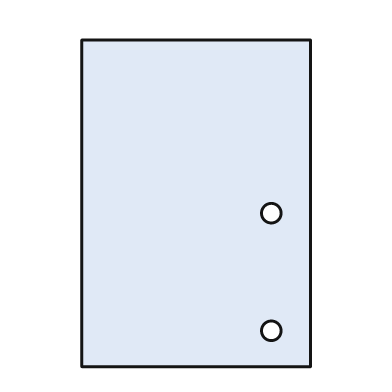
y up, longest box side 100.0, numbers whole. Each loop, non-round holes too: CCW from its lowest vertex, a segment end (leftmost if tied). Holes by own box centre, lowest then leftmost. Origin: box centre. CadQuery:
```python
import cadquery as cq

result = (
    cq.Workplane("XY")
    .moveTo(-35.0, -50.0)
    .lineTo(35.0, -50.0)
    .lineTo(35.0, 50.0)
    .lineTo(-35.0, 50.0)
    .close()
    .moveTo(23.0, -39.0)
    .circle(3.0)
    .moveTo(23.0, -3.0)
    .circle(3.0)
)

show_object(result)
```